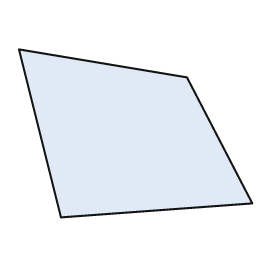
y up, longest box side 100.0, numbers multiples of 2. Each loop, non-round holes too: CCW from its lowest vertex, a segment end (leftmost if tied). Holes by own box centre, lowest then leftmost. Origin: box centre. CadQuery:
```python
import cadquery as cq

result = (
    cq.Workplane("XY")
    .moveTo(-32.0, -36.0)
    .lineTo(50.0, -30.0)
    .lineTo(22.0, 24.0)
    .lineTo(-50.0, 36.0)
    .close()
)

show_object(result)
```